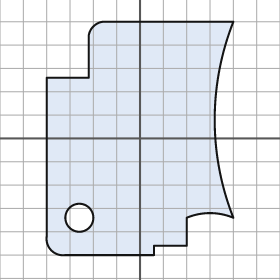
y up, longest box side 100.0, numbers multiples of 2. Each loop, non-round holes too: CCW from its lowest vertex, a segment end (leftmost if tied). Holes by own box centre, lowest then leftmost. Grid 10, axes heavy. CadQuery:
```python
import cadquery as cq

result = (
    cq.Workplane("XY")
    .moveTo(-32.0, -50.0)
    .lineTo(6.0, -50.0)
    .lineTo(6.0, -46.0)
    .lineTo(20.0, -46.0)
    .lineTo(20.0, -34.0)
    .threePointArc((30.0, -32.0), (40.0, -34.0))
    .threePointArc((32.0, 8.0), (40.0, 50.0))
    .lineTo(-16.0, 50.0)
    .threePointArc((-20.0, 48.0), (-22.0, 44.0))
    .lineTo(-22.0, 26.0)
    .lineTo(-40.0, 26.0)
    .lineTo(-40.0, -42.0)
    .threePointArc((-38.0, -48.0), (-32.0, -50.0))
    .close()
    .moveTo(-26.0, -34.0)
    .circle(6.0)
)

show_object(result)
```